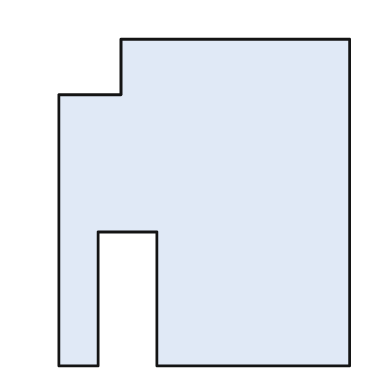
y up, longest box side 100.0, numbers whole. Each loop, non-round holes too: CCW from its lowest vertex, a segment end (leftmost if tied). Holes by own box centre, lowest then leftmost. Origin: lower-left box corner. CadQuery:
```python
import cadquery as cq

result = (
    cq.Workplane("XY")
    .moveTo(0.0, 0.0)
    .lineTo(12.0, 0.0)
    .lineTo(12.0, 41.0)
    .lineTo(30.0, 41.0)
    .lineTo(30.0, 0.0)
    .lineTo(89.0, 0.0)
    .lineTo(89.0, 100.0)
    .lineTo(19.0, 100.0)
    .lineTo(19.0, 83.0)
    .lineTo(0.0, 83.0)
    .close()
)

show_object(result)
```